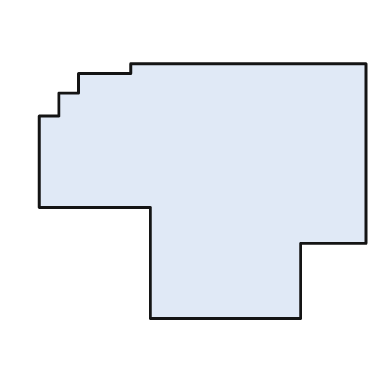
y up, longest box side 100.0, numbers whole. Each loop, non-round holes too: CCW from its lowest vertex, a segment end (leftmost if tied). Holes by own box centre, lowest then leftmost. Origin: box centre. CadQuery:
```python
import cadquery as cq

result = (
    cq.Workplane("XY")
    .moveTo(-16.0, -39.0)
    .lineTo(30.0, -39.0)
    .lineTo(30.0, -16.0)
    .lineTo(50.0, -16.0)
    .lineTo(50.0, 39.0)
    .lineTo(-22.0, 39.0)
    .lineTo(-22.0, 36.0)
    .lineTo(-38.0, 36.0)
    .lineTo(-38.0, 30.0)
    .lineTo(-44.0, 30.0)
    .lineTo(-44.0, 23.0)
    .lineTo(-50.0, 23.0)
    .lineTo(-50.0, -5.0)
    .lineTo(-16.0, -5.0)
    .close()
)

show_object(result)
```